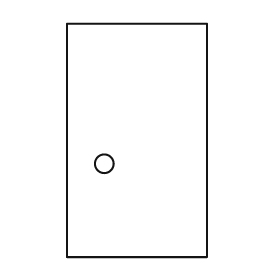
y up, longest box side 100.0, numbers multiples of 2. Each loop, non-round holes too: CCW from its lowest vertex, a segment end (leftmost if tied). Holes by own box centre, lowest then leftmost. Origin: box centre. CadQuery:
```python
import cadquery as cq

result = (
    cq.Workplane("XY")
    .moveTo(-30.0, -50.0)
    .lineTo(30.0, -50.0)
    .lineTo(30.0, 50.0)
    .lineTo(-30.0, 50.0)
    .close()
    .moveTo(-14.0, -10.0)
    .circle(4.0)
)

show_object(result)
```